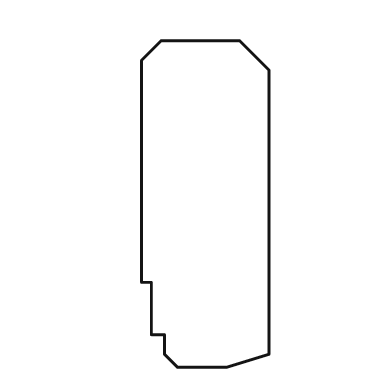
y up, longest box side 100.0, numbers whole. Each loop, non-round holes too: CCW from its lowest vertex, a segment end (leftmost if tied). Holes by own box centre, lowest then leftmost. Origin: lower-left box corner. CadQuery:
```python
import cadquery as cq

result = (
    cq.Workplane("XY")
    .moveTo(11.0, 0.0)
    .lineTo(26.0, 0.0)
    .lineTo(39.0, 4.0)
    .lineTo(39.0, 91.0)
    .lineTo(30.0, 100.0)
    .lineTo(6.0, 100.0)
    .lineTo(0.0, 94.0)
    .lineTo(0.0, 26.0)
    .lineTo(3.0, 26.0)
    .lineTo(3.0, 10.0)
    .lineTo(7.0, 10.0)
    .lineTo(7.0, 4.0)
    .close()
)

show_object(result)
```